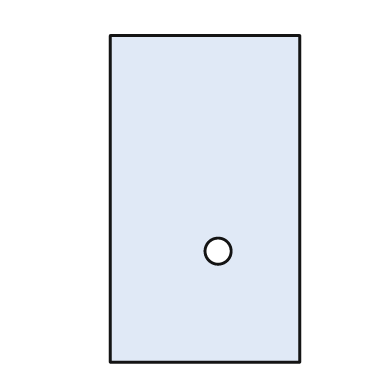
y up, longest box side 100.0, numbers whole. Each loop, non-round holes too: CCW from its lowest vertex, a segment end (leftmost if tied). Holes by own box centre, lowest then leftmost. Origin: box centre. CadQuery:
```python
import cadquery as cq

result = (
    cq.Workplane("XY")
    .moveTo(-29.0, -50.0)
    .lineTo(29.0, -50.0)
    .lineTo(29.0, 50.0)
    .lineTo(-29.0, 50.0)
    .close()
    .moveTo(4.0, -16.0)
    .circle(4.0)
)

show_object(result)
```